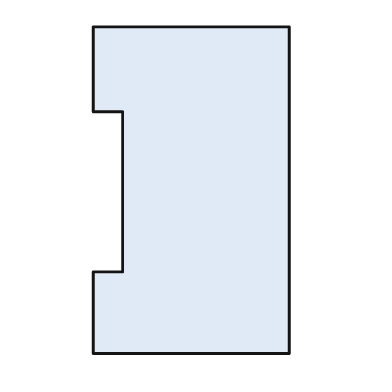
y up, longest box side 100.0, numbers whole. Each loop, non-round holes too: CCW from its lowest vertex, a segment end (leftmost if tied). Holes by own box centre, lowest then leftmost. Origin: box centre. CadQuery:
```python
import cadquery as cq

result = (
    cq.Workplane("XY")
    .moveTo(-30.0, -50.0)
    .lineTo(30.0, -50.0)
    .lineTo(30.0, 50.0)
    .lineTo(-30.0, 50.0)
    .lineTo(-30.0, 24.0)
    .lineTo(-21.0, 24.0)
    .lineTo(-21.0, -25.0)
    .lineTo(-30.0, -25.0)
    .close()
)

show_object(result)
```